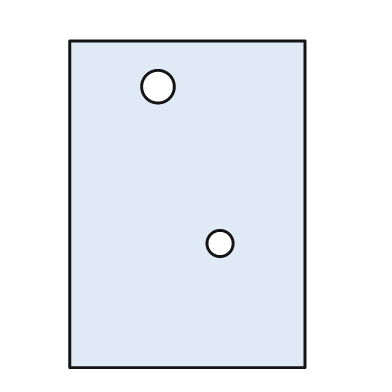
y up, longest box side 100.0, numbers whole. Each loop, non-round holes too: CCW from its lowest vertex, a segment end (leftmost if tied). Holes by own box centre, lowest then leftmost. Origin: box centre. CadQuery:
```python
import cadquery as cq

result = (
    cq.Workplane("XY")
    .moveTo(-36.0, -50.0)
    .lineTo(36.0, -50.0)
    .lineTo(36.0, 50.0)
    .lineTo(-36.0, 50.0)
    .close()
    .moveTo(10.0, -12.0)
    .circle(4.0)
    .moveTo(-9.0, 36.0)
    .circle(5.0)
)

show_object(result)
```